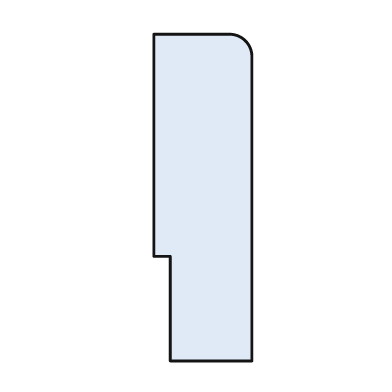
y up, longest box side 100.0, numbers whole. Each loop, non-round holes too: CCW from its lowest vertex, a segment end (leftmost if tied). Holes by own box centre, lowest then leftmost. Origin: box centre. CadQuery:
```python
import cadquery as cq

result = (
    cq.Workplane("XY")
    .moveTo(-10.0, -50.0)
    .lineTo(15.0, -50.0)
    .lineTo(15.0, 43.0)
    .threePointArc((13.0, 48.0), (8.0, 50.0))
    .lineTo(-15.0, 50.0)
    .lineTo(-15.0, -18.0)
    .lineTo(-10.0, -18.0)
    .close()
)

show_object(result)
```